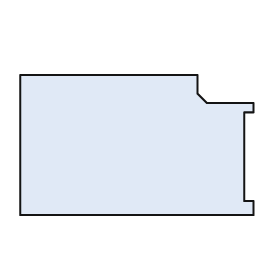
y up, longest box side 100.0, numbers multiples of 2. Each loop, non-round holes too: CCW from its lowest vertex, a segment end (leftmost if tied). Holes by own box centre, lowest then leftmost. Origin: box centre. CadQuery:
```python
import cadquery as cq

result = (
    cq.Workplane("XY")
    .moveTo(-50.0, -30.0)
    .lineTo(50.0, -30.0)
    .lineTo(50.0, -24.0)
    .lineTo(46.0, -24.0)
    .lineTo(46.0, 14.0)
    .lineTo(50.0, 14.0)
    .lineTo(50.0, 18.0)
    .lineTo(30.0, 18.0)
    .lineTo(26.0, 22.0)
    .lineTo(26.0, 30.0)
    .lineTo(-50.0, 30.0)
    .close()
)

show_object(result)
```